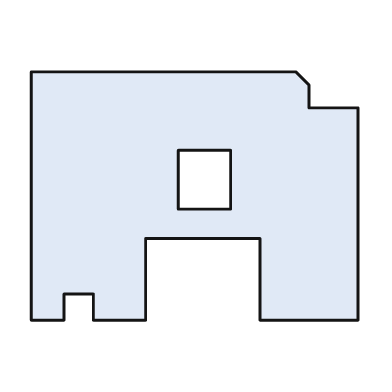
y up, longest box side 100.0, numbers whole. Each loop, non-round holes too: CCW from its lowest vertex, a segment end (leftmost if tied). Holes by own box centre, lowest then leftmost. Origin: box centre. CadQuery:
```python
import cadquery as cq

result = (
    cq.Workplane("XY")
    .moveTo(-50.0, -38.0)
    .lineTo(-40.0, -38.0)
    .lineTo(-40.0, -30.0)
    .lineTo(-31.0, -30.0)
    .lineTo(-31.0, -38.0)
    .lineTo(-15.0, -38.0)
    .lineTo(-15.0, -13.0)
    .lineTo(20.0, -13.0)
    .lineTo(20.0, -38.0)
    .lineTo(50.0, -38.0)
    .lineTo(50.0, 27.0)
    .lineTo(35.0, 27.0)
    .lineTo(35.0, 34.0)
    .lineTo(31.0, 38.0)
    .lineTo(-50.0, 38.0)
    .close()
    .moveTo(-5.0, -4.0)
    .lineTo(11.0, -4.0)
    .lineTo(11.0, 14.0)
    .lineTo(-5.0, 14.0)
    .close()
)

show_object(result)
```